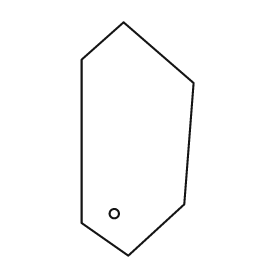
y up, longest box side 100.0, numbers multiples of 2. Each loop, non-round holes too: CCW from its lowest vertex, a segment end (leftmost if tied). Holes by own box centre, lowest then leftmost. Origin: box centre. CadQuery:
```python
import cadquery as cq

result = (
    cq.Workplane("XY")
    .moveTo(-4.0, -50.0)
    .lineTo(20.0, -28.0)
    .lineTo(24.0, 24.0)
    .lineTo(-6.0, 50.0)
    .lineTo(-24.0, 34.0)
    .lineTo(-24.0, -36.0)
    .close()
    .moveTo(-10.0, -32.0)
    .circle(2.0)
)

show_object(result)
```